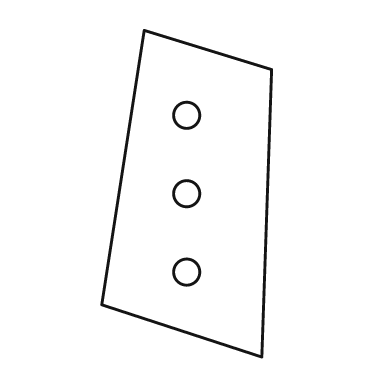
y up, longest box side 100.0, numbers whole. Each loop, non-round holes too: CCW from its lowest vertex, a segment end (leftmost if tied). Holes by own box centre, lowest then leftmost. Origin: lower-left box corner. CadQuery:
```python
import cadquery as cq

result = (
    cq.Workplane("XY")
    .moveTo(49.0, 0.0)
    .lineTo(52.0, 88.0)
    .lineTo(13.0, 100.0)
    .lineTo(0.0, 16.0)
    .close()
    .moveTo(26.0, 26.0)
    .circle(4.0)
    .moveTo(26.0, 50.0)
    .circle(4.0)
    .moveTo(26.0, 74.0)
    .circle(4.0)
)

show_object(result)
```